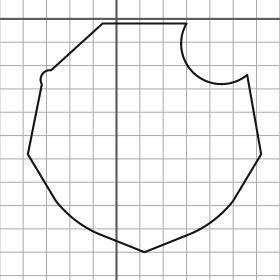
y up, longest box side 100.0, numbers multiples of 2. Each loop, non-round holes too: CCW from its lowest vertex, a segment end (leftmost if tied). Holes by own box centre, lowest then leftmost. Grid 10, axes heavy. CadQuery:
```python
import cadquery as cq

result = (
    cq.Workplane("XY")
    .moveTo(12.0, -100.0)
    .lineTo(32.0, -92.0)
    .threePointArc((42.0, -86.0), (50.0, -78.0))
    .lineTo(62.0, -58.0)
    .lineTo(56.0, -24.0)
    .threePointArc((34.0, -24.0), (30.0, -2.0))
    .lineTo(-6.0, -2.0)
    .lineTo(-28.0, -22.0)
    .threePointArc((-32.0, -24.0), (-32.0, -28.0))
    .lineTo(-38.0, -58.0)
    .lineTo(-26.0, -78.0)
    .threePointArc((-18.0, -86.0), (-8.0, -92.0))
    .close()
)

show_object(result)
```